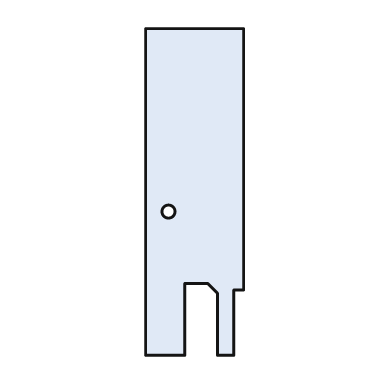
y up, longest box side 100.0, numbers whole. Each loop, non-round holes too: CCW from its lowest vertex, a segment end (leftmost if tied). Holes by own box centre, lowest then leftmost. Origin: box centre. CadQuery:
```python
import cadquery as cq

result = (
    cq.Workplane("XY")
    .moveTo(-15.0, -50.0)
    .lineTo(-3.0, -50.0)
    .lineTo(-3.0, -28.0)
    .lineTo(4.0, -28.0)
    .lineTo(7.0, -31.0)
    .lineTo(7.0, -50.0)
    .lineTo(12.0, -50.0)
    .lineTo(12.0, -30.0)
    .lineTo(15.0, -30.0)
    .lineTo(15.0, 50.0)
    .lineTo(-15.0, 50.0)
    .close()
    .moveTo(-8.0, -6.0)
    .circle(2.0)
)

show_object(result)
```